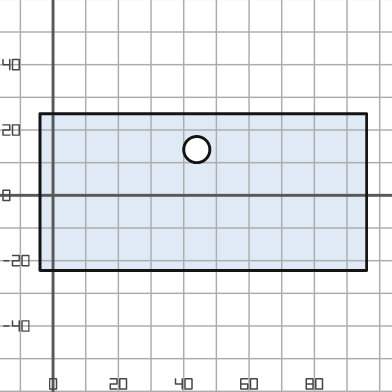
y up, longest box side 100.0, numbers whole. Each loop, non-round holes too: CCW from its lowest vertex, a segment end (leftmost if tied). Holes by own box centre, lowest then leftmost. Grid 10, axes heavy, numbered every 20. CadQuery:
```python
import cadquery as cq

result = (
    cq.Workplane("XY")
    .moveTo(-4.0, -23.0)
    .lineTo(96.0, -23.0)
    .lineTo(96.0, 25.0)
    .lineTo(-4.0, 25.0)
    .close()
    .moveTo(44.0, 14.0)
    .circle(4.0)
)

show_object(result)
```